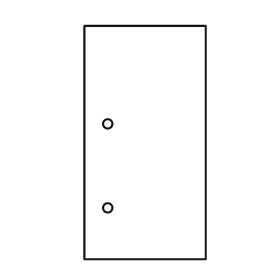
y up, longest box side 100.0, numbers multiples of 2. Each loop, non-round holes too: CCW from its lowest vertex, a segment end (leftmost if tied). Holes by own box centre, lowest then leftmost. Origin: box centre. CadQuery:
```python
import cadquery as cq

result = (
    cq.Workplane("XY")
    .moveTo(-26.0, -50.0)
    .lineTo(26.0, -50.0)
    .lineTo(26.0, 50.0)
    .lineTo(-26.0, 50.0)
    .close()
    .moveTo(-16.0, -28.0)
    .circle(2.0)
    .moveTo(-16.0, 8.0)
    .circle(2.0)
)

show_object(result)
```